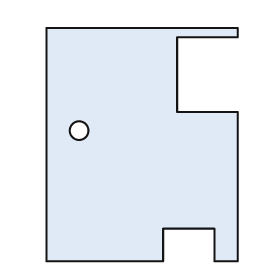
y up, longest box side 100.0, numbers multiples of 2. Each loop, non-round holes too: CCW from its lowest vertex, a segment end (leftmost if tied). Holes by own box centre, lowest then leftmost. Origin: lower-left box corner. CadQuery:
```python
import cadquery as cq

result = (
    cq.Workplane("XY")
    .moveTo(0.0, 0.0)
    .lineTo(50.0, 0.0)
    .lineTo(50.0, 14.0)
    .lineTo(72.0, 14.0)
    .lineTo(72.0, 0.0)
    .lineTo(82.0, 0.0)
    .lineTo(82.0, 64.0)
    .lineTo(56.0, 64.0)
    .lineTo(56.0, 96.0)
    .lineTo(82.0, 96.0)
    .lineTo(82.0, 100.0)
    .lineTo(0.0, 100.0)
    .close()
    .moveTo(14.0, 56.0)
    .circle(4.0)
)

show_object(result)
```